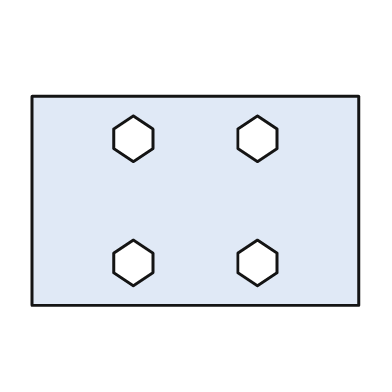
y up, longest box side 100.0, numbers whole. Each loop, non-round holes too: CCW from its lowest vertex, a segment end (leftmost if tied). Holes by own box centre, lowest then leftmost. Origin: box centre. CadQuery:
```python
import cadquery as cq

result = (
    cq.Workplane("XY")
    .moveTo(-50.0, -32.0)
    .lineTo(50.0, -32.0)
    .lineTo(50.0, 32.0)
    .lineTo(-50.0, 32.0)
    .close()
    .moveTo(-19.0, -26.0)
    .lineTo(-13.0, -22.0)
    .lineTo(-13.0, -16.0)
    .lineTo(-19.0, -12.0)
    .lineTo(-25.0, -16.0)
    .lineTo(-25.0, -22.0)
    .close()
    .moveTo(19.0, -26.0)
    .lineTo(25.0, -22.0)
    .lineTo(25.0, -16.0)
    .lineTo(19.0, -12.0)
    .lineTo(13.0, -16.0)
    .lineTo(13.0, -22.0)
    .close()
    .moveTo(-19.0, 12.0)
    .lineTo(-13.0, 16.0)
    .lineTo(-13.0, 22.0)
    .lineTo(-19.0, 26.0)
    .lineTo(-25.0, 22.0)
    .lineTo(-25.0, 16.0)
    .close()
    .moveTo(19.0, 12.0)
    .lineTo(25.0, 16.0)
    .lineTo(25.0, 22.0)
    .lineTo(19.0, 26.0)
    .lineTo(13.0, 22.0)
    .lineTo(13.0, 16.0)
    .close()
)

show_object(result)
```